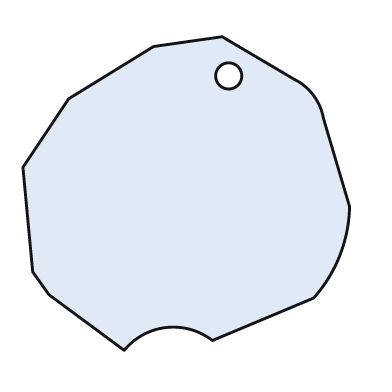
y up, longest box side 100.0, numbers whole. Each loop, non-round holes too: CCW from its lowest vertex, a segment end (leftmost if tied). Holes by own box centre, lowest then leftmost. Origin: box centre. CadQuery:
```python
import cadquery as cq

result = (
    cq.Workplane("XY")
    .moveTo(-19.0, -48.0)
    .threePointArc((-6.0, -41.0), (8.0, -45.0))
    .lineTo(39.0, -32.0)
    .threePointArc((47.0, -19.0), (50.0, -4.0))
    .lineTo(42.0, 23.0)
    .threePointArc((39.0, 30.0), (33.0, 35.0))
    .lineTo(11.0, 48.0)
    .lineTo(-10.0, 45.0)
    .lineTo(-36.0, 29.0)
    .lineTo(-50.0, 8.0)
    .lineTo(-47.0, -24.0)
    .lineTo(-42.0, -31.0)
    .close()
    .moveTo(13.0, 36.0)
    .circle(4.0)
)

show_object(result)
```